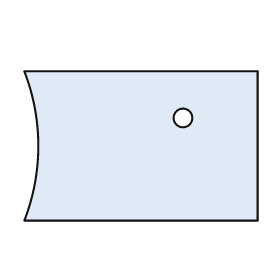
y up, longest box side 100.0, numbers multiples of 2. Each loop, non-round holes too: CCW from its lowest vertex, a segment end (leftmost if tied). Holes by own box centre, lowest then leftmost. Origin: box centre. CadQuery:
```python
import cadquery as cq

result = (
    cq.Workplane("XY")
    .moveTo(-50.0, -32.0)
    .lineTo(50.0, -32.0)
    .lineTo(50.0, 32.0)
    .lineTo(-50.0, 32.0)
    .threePointArc((-44.0, 0.0), (-50.0, -32.0))
    .close()
    .moveTo(18.0, 12.0)
    .circle(4.0)
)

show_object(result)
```